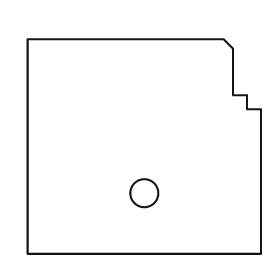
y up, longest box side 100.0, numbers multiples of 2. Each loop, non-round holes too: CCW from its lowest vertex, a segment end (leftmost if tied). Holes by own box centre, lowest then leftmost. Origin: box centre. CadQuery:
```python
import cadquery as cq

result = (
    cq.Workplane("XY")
    .moveTo(-50.0, -46.0)
    .lineTo(50.0, -46.0)
    .lineTo(50.0, 16.0)
    .lineTo(44.0, 16.0)
    .lineTo(44.0, 22.0)
    .lineTo(38.0, 22.0)
    .lineTo(38.0, 42.0)
    .lineTo(34.0, 46.0)
    .lineTo(-50.0, 46.0)
    .close()
    .moveTo(0.0, -20.0)
    .circle(6.0)
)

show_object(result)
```